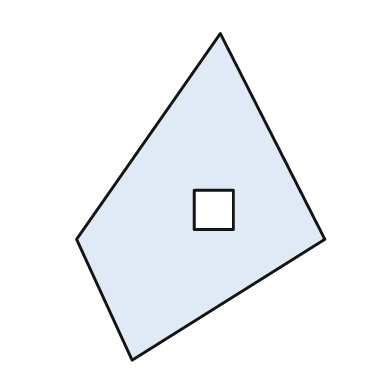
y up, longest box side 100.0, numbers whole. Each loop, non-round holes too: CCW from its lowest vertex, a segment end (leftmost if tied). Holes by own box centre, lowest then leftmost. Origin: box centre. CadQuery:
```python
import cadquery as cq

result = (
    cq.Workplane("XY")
    .moveTo(-21.0, -50.0)
    .lineTo(38.0, -13.0)
    .lineTo(6.0, 50.0)
    .lineTo(-38.0, -13.0)
    .close()
    .moveTo(-2.0, -10.0)
    .lineTo(10.0, -10.0)
    .lineTo(10.0, 2.0)
    .lineTo(-2.0, 2.0)
    .close()
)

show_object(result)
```